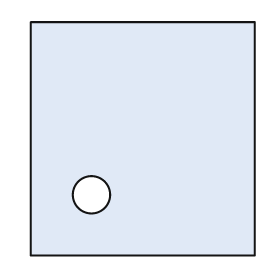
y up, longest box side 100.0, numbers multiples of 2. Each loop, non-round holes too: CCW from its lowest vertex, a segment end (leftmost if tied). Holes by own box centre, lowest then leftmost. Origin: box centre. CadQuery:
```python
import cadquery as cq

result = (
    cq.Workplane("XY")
    .moveTo(-48.0, -50.0)
    .lineTo(48.0, -50.0)
    .lineTo(48.0, 50.0)
    .lineTo(-48.0, 50.0)
    .close()
    .moveTo(-22.0, -24.0)
    .circle(8.0)
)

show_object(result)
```